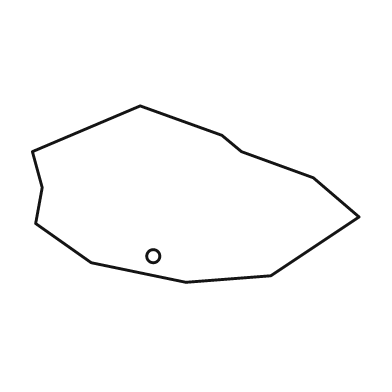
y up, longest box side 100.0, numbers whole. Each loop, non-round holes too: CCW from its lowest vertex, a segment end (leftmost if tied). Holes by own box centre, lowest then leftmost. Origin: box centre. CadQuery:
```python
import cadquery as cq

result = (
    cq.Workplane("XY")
    .moveTo(-3.0, -27.0)
    .lineTo(23.0, -25.0)
    .lineTo(50.0, -7.0)
    .lineTo(36.0, 5.0)
    .lineTo(14.0, 13.0)
    .lineTo(8.0, 18.0)
    .lineTo(-17.0, 27.0)
    .lineTo(-50.0, 13.0)
    .lineTo(-47.0, 2.0)
    .lineTo(-49.0, -9.0)
    .lineTo(-32.0, -21.0)
    .close()
    .moveTo(-13.0, -19.0)
    .circle(2.0)
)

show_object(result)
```